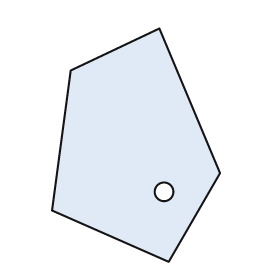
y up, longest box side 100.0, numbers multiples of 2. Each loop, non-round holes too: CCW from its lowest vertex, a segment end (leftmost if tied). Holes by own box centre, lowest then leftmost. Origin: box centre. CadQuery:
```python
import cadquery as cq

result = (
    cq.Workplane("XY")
    .moveTo(14.0, -50.0)
    .lineTo(36.0, -12.0)
    .lineTo(10.0, 50.0)
    .lineTo(-28.0, 32.0)
    .lineTo(-36.0, -28.0)
    .close()
    .moveTo(12.0, -20.0)
    .circle(4.0)
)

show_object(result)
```